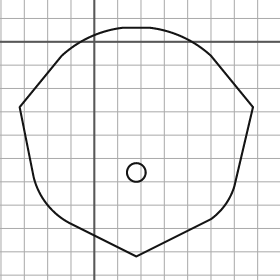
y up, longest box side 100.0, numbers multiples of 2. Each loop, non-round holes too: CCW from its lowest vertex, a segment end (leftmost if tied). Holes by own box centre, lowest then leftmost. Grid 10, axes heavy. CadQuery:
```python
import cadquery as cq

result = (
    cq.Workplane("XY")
    .moveTo(18.0, -92.0)
    .lineTo(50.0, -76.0)
    .threePointArc((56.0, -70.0), (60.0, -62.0))
    .lineTo(68.0, -28.0)
    .lineTo(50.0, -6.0)
    .threePointArc((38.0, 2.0), (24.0, 6.0))
    .lineTo(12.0, 6.0)
    .threePointArc((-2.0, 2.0), (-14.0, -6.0))
    .lineTo(-32.0, -28.0)
    .lineTo(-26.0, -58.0)
    .threePointArc((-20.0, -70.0), (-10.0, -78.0))
    .close()
    .moveTo(18.0, -56.0)
    .circle(4.0)
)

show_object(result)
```